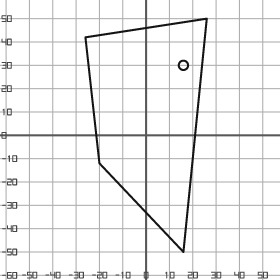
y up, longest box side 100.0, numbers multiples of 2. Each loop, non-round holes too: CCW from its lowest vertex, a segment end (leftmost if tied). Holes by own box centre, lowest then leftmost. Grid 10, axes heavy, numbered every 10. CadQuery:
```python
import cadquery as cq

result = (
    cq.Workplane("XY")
    .moveTo(16.0, -50.0)
    .lineTo(26.0, 50.0)
    .lineTo(-26.0, 42.0)
    .lineTo(-20.0, -12.0)
    .close()
    .moveTo(16.0, 30.0)
    .circle(2.0)
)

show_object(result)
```